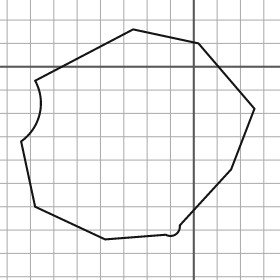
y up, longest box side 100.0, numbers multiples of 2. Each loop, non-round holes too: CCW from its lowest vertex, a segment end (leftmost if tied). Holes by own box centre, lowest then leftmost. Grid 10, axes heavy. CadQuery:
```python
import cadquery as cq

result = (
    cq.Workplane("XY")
    .moveTo(-38.0, -74.0)
    .lineTo(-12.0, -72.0)
    .threePointArc((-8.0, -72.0), (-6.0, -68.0))
    .lineTo(16.0, -44.0)
    .lineTo(26.0, -18.0)
    .lineTo(2.0, 10.0)
    .lineTo(-26.0, 16.0)
    .lineTo(-68.0, -6.0)
    .threePointArc((-66.0, -20.0), (-74.0, -32.0))
    .lineTo(-68.0, -60.0)
    .close()
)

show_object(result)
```